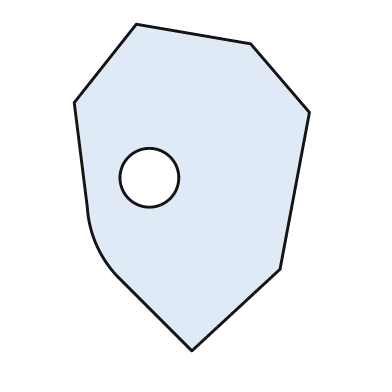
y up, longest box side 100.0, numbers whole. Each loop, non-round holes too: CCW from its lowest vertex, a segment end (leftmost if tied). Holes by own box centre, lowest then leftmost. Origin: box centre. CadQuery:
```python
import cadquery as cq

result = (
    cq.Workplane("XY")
    .moveTo(0.0, -50.0)
    .lineTo(27.0, -25.0)
    .lineTo(36.0, 23.0)
    .lineTo(18.0, 44.0)
    .lineTo(-17.0, 50.0)
    .lineTo(-36.0, 26.0)
    .lineTo(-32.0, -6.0)
    .threePointArc((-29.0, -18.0), (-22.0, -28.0))
    .close()
    .moveTo(-13.0, 3.0)
    .circle(9.0)
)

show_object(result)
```